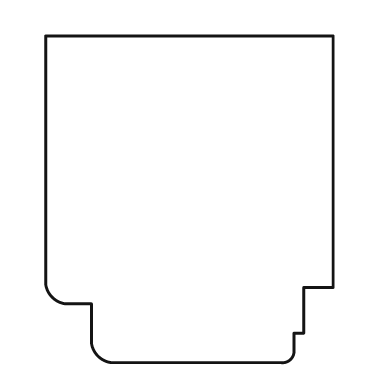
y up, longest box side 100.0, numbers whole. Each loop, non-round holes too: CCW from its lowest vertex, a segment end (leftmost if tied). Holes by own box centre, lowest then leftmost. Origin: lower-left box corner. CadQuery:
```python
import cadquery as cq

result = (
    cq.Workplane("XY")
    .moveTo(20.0, 0.0)
    .lineTo(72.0, 0.0)
    .threePointArc((75.0, 1.0), (76.0, 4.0))
    .lineTo(76.0, 9.0)
    .lineTo(79.0, 9.0)
    .lineTo(79.0, 23.0)
    .lineTo(88.0, 23.0)
    .lineTo(88.0, 100.0)
    .lineTo(0.0, 100.0)
    .lineTo(0.0, 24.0)
    .threePointArc((2.0, 20.0), (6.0, 18.0))
    .lineTo(14.0, 18.0)
    .lineTo(14.0, 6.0)
    .threePointArc((16.0, 2.0), (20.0, 0.0))
    .close()
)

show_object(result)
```